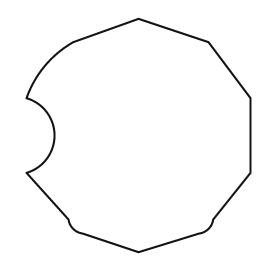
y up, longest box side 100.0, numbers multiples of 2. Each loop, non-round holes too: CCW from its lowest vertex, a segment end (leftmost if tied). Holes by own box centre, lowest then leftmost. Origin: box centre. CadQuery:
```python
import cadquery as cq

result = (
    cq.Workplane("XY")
    .moveTo(0.0, -50.0)
    .lineTo(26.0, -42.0)
    .threePointArc((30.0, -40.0), (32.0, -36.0))
    .lineTo(48.0, -16.0)
    .lineTo(48.0, 16.0)
    .lineTo(30.0, 40.0)
    .lineTo(0.0, 50.0)
    .lineTo(-28.0, 40.0)
    .threePointArc((-40.0, 30.0), (-48.0, 16.0))
    .threePointArc((-36.0, 0.0), (-48.0, -16.0))
    .lineTo(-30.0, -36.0)
    .threePointArc((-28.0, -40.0), (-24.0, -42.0))
    .close()
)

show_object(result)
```